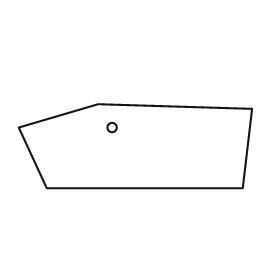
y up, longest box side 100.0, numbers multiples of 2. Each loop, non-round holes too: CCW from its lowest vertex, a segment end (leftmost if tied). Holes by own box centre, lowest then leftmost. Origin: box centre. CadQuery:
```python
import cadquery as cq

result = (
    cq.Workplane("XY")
    .moveTo(-38.0, -18.0)
    .lineTo(46.0, -18.0)
    .lineTo(50.0, 16.0)
    .lineTo(-16.0, 18.0)
    .lineTo(-50.0, 8.0)
    .close()
    .moveTo(-10.0, 8.0)
    .circle(2.0)
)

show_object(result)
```